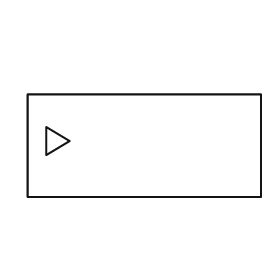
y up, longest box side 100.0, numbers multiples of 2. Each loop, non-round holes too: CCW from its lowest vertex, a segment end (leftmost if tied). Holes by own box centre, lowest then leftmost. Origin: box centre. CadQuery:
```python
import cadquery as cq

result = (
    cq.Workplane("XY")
    .moveTo(-50.0, -22.0)
    .lineTo(50.0, -22.0)
    .lineTo(50.0, 22.0)
    .lineTo(-50.0, 22.0)
    .close()
    .moveTo(-42.0, -4.0)
    .lineTo(-32.0, 2.0)
    .lineTo(-42.0, 8.0)
    .close()
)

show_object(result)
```